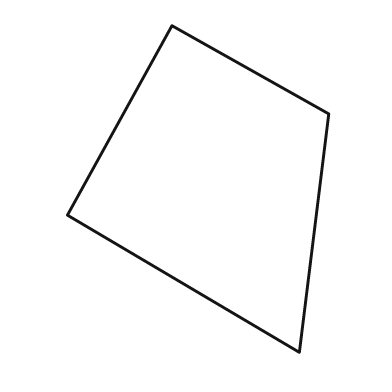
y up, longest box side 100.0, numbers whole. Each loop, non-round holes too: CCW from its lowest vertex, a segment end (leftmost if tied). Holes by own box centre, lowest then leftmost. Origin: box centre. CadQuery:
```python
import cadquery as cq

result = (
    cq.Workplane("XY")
    .moveTo(31.0, -50.0)
    .lineTo(40.0, 23.0)
    .lineTo(-8.0, 50.0)
    .lineTo(-40.0, -8.0)
    .close()
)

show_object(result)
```